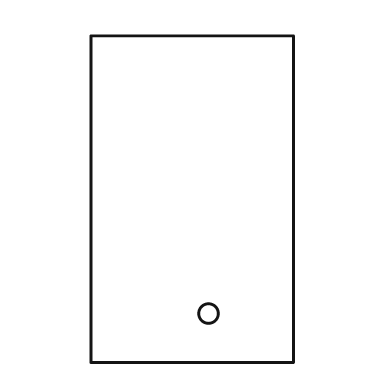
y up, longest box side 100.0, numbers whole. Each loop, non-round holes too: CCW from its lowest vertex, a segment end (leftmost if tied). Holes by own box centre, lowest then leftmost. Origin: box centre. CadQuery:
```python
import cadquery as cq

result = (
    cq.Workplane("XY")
    .moveTo(-31.0, -50.0)
    .lineTo(31.0, -50.0)
    .lineTo(31.0, 50.0)
    .lineTo(-31.0, 50.0)
    .close()
    .moveTo(5.0, -35.0)
    .circle(3.0)
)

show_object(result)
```